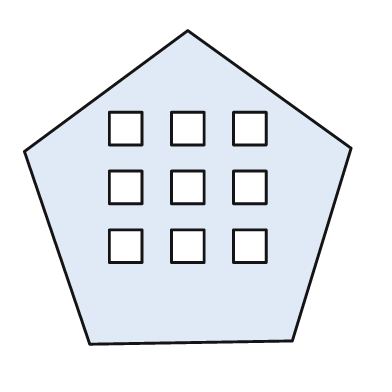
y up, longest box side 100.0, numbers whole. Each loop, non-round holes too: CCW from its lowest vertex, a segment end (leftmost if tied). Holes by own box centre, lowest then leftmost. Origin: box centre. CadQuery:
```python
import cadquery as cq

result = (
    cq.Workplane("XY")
    .moveTo(-30.0, -48.0)
    .lineTo(32.0, -47.0)
    .lineTo(50.0, 12.0)
    .lineTo(0.0, 48.0)
    .lineTo(-50.0, 11.0)
    .close()
    .moveTo(-24.0, -23.0)
    .lineTo(-14.0, -23.0)
    .lineTo(-14.0, -13.0)
    .lineTo(-24.0, -13.0)
    .close()
    .moveTo(-5.0, -23.0)
    .lineTo(5.0, -23.0)
    .lineTo(5.0, -13.0)
    .lineTo(-5.0, -13.0)
    .close()
    .moveTo(14.0, -23.0)
    .lineTo(24.0, -23.0)
    .lineTo(24.0, -13.0)
    .lineTo(14.0, -13.0)
    .close()
    .moveTo(-24.0, -5.0)
    .lineTo(-14.0, -5.0)
    .lineTo(-14.0, 5.0)
    .lineTo(-24.0, 5.0)
    .close()
    .moveTo(-5.0, -5.0)
    .lineTo(5.0, -5.0)
    .lineTo(5.0, 5.0)
    .lineTo(-5.0, 5.0)
    .close()
    .moveTo(14.0, -5.0)
    .lineTo(24.0, -5.0)
    .lineTo(24.0, 5.0)
    .lineTo(14.0, 5.0)
    .close()
    .moveTo(-24.0, 13.0)
    .lineTo(-14.0, 13.0)
    .lineTo(-14.0, 23.0)
    .lineTo(-24.0, 23.0)
    .close()
    .moveTo(-5.0, 13.0)
    .lineTo(5.0, 13.0)
    .lineTo(5.0, 23.0)
    .lineTo(-5.0, 23.0)
    .close()
    .moveTo(14.0, 13.0)
    .lineTo(24.0, 13.0)
    .lineTo(24.0, 23.0)
    .lineTo(14.0, 23.0)
    .close()
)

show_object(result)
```